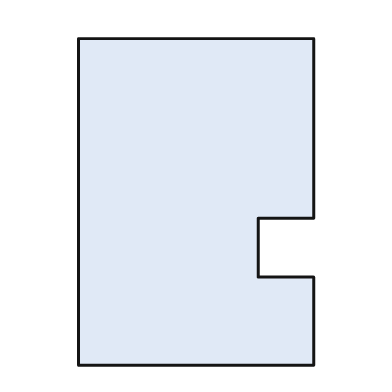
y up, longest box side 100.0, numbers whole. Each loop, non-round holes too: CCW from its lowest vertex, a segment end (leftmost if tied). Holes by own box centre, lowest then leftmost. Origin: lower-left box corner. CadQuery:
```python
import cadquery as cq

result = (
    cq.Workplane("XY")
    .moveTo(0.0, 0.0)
    .lineTo(72.0, 0.0)
    .lineTo(72.0, 27.0)
    .lineTo(55.0, 27.0)
    .lineTo(55.0, 45.0)
    .lineTo(72.0, 45.0)
    .lineTo(72.0, 100.0)
    .lineTo(0.0, 100.0)
    .close()
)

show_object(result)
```